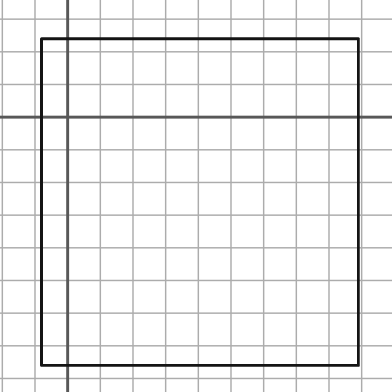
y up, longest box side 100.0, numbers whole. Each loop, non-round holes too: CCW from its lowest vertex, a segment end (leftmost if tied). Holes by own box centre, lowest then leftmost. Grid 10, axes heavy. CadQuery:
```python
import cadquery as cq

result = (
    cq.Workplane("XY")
    .moveTo(-8.0, -76.0)
    .lineTo(89.0, -76.0)
    .lineTo(89.0, 24.0)
    .lineTo(-8.0, 24.0)
    .close()
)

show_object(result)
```